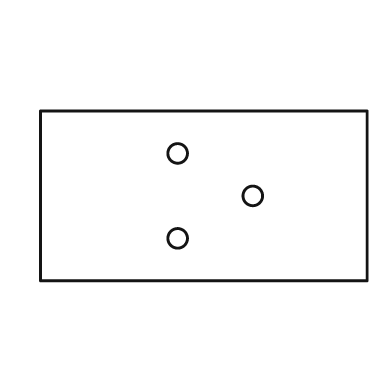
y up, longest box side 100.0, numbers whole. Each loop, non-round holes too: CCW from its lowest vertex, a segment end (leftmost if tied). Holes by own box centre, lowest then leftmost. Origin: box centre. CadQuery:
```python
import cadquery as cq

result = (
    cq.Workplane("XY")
    .moveTo(-50.0, -26.0)
    .lineTo(50.0, -26.0)
    .lineTo(50.0, 26.0)
    .lineTo(-50.0, 26.0)
    .close()
    .moveTo(-8.0, -13.0)
    .circle(3.0)
    .moveTo(15.0, 0.0)
    .circle(3.0)
    .moveTo(-8.0, 13.0)
    .circle(3.0)
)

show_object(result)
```